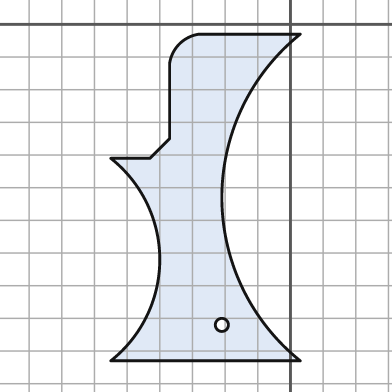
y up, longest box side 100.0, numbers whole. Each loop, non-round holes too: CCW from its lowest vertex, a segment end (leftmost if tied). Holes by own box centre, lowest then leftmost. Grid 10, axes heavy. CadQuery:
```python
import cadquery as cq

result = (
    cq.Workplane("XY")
    .moveTo(-55.0, -103.0)
    .lineTo(3.0, -103.0)
    .threePointArc((-21.0, -53.0), (3.0, -3.0))
    .lineTo(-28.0, -3.0)
    .threePointArc((-34.0, -6.0), (-37.0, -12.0))
    .lineTo(-37.0, -35.0)
    .lineTo(-43.0, -41.0)
    .lineTo(-55.0, -41.0)
    .threePointArc((-40.0, -72.0), (-55.0, -103.0))
    .close()
    .moveTo(-21.0, -92.0)
    .circle(2.0)
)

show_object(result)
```